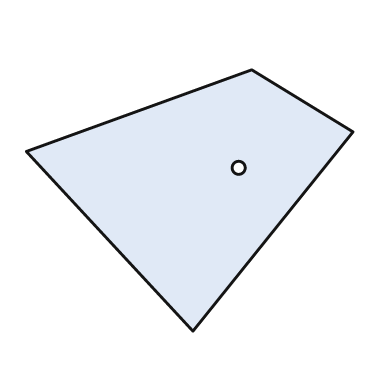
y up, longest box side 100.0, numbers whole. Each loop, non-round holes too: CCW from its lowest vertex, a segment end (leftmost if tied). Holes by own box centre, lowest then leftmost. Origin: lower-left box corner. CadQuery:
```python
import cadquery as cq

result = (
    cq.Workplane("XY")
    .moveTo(51.0, 0.0)
    .lineTo(100.0, 61.0)
    .lineTo(69.0, 80.0)
    .lineTo(0.0, 55.0)
    .close()
    .moveTo(65.0, 50.0)
    .circle(2.0)
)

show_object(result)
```